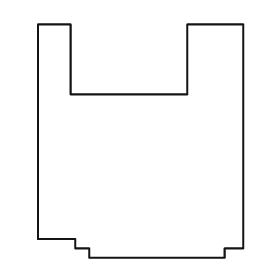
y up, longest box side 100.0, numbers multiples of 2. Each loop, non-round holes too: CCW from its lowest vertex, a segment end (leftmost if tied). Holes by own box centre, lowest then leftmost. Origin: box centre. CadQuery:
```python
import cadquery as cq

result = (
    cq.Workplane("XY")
    .moveTo(-22.0, -50.0)
    .lineTo(36.0, -50.0)
    .lineTo(36.0, -46.0)
    .lineTo(44.0, -46.0)
    .lineTo(44.0, 50.0)
    .lineTo(20.0, 50.0)
    .lineTo(20.0, 20.0)
    .lineTo(-30.0, 20.0)
    .lineTo(-30.0, 50.0)
    .lineTo(-44.0, 50.0)
    .lineTo(-44.0, -42.0)
    .lineTo(-28.0, -42.0)
    .lineTo(-28.0, -46.0)
    .lineTo(-22.0, -46.0)
    .close()
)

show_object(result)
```